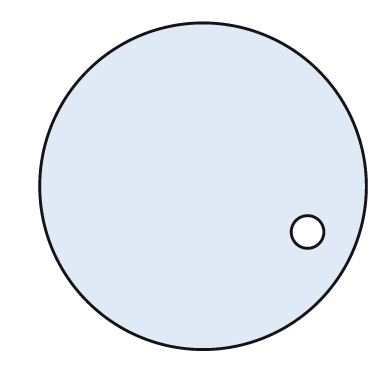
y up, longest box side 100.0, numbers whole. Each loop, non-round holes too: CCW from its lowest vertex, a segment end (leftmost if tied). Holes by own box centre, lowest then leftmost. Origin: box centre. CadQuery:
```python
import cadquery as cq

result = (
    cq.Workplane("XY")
    .moveTo(0.0, 0.0)
    .circle(50.0)
    .moveTo(32.0, -14.0)
    .circle(5.0)
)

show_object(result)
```